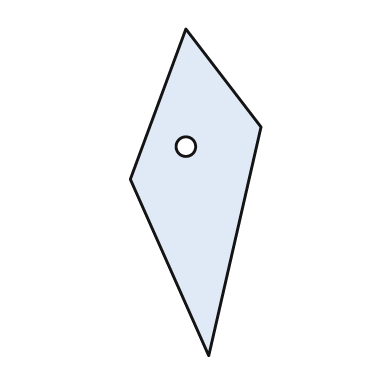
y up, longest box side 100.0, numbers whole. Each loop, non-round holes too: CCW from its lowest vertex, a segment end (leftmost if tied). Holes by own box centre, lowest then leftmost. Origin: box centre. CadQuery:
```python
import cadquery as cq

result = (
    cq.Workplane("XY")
    .moveTo(4.0, -50.0)
    .lineTo(20.0, 20.0)
    .lineTo(-3.0, 50.0)
    .lineTo(-20.0, 4.0)
    .close()
    .moveTo(-3.0, 14.0)
    .circle(3.0)
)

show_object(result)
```